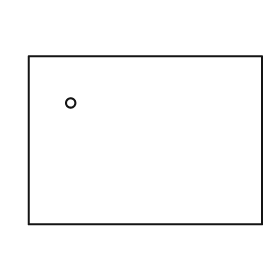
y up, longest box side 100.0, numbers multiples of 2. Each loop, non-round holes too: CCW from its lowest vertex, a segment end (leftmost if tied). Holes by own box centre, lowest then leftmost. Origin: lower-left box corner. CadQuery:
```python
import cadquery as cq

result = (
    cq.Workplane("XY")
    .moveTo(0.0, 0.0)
    .lineTo(100.0, 0.0)
    .lineTo(100.0, 72.0)
    .lineTo(0.0, 72.0)
    .close()
    .moveTo(18.0, 52.0)
    .circle(2.0)
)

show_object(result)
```